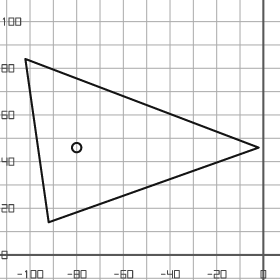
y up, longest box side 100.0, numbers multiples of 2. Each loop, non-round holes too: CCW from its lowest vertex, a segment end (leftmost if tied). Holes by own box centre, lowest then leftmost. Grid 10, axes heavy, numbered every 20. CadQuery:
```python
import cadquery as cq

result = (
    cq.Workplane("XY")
    .moveTo(-92.0, 14.0)
    .lineTo(-2.0, 46.0)
    .lineTo(-102.0, 84.0)
    .close()
    .moveTo(-80.0, 46.0)
    .circle(2.0)
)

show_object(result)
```